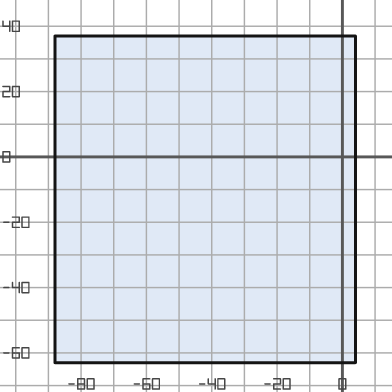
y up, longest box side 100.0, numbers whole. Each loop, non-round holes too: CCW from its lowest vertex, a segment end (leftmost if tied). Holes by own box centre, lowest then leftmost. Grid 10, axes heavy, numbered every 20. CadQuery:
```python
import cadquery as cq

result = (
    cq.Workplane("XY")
    .moveTo(-88.0, -63.0)
    .lineTo(4.0, -63.0)
    .lineTo(4.0, 37.0)
    .lineTo(-88.0, 37.0)
    .close()
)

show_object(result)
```